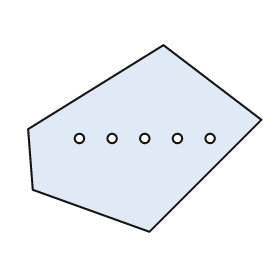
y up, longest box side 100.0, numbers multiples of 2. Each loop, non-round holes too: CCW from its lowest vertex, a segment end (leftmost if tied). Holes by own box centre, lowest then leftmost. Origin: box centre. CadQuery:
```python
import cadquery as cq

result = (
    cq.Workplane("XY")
    .moveTo(2.0, -40.0)
    .lineTo(50.0, 8.0)
    .lineTo(8.0, 40.0)
    .lineTo(-50.0, 4.0)
    .lineTo(-48.0, -22.0)
    .close()
    .moveTo(-28.0, 0.0)
    .circle(2.0)
    .moveTo(-14.0, 0.0)
    .circle(2.0)
    .moveTo(0.0, 0.0)
    .circle(2.0)
    .moveTo(14.0, 0.0)
    .circle(2.0)
    .moveTo(28.0, 0.0)
    .circle(2.0)
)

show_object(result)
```